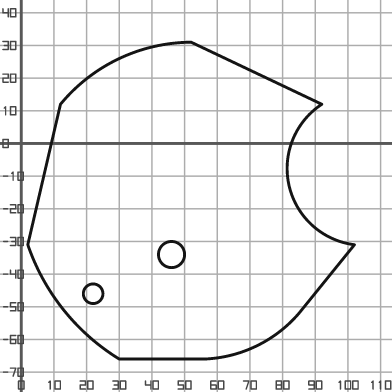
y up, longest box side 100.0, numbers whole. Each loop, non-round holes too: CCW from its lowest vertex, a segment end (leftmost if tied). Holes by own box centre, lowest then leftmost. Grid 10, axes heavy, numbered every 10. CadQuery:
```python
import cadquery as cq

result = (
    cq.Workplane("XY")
    .moveTo(30.0, -66.0)
    .lineTo(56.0, -66.0)
    .threePointArc((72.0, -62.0), (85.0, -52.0))
    .lineTo(102.0, -31.0)
    .threePointArc((82.0, -13.0), (92.0, 12.0))
    .lineTo(52.0, 31.0)
    .threePointArc((30.0, 26.0), (12.0, 12.0))
    .lineTo(2.0, -31.0)
    .threePointArc((13.0, -51.0), (30.0, -66.0))
    .close()
    .moveTo(22.0, -46.0)
    .circle(3.0)
    .moveTo(46.0, -34.0)
    .circle(4.0)
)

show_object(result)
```